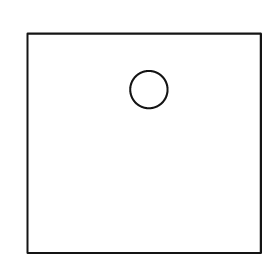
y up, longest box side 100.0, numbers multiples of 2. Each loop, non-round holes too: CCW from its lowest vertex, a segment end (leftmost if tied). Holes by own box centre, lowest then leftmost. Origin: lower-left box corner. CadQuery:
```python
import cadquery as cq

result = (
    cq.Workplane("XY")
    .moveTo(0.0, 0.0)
    .lineTo(100.0, 0.0)
    .lineTo(100.0, 94.0)
    .lineTo(0.0, 94.0)
    .close()
    .moveTo(52.0, 70.0)
    .circle(8.0)
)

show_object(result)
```